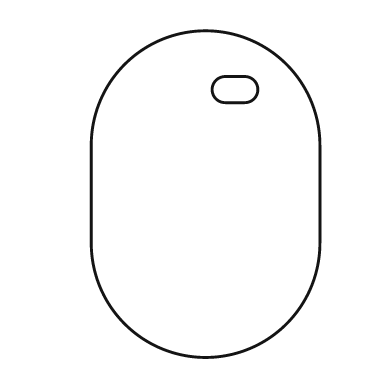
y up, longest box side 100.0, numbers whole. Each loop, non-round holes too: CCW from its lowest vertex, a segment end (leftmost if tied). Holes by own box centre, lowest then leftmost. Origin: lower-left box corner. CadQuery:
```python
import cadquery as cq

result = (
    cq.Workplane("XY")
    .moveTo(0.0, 35.0)
    .threePointArc((35.0, 0.0), (70.0, 35.0))
    .lineTo(70.0, 65.0)
    .threePointArc((35.0, 100.0), (0.0, 65.0))
    .close()
    .moveTo(41.0, 78.0)
    .lineTo(47.0, 78.0)
    .threePointArc((51.0, 82.0), (47.0, 86.0))
    .lineTo(41.0, 86.0)
    .threePointArc((37.0, 82.0), (41.0, 78.0))
    .close()
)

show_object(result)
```